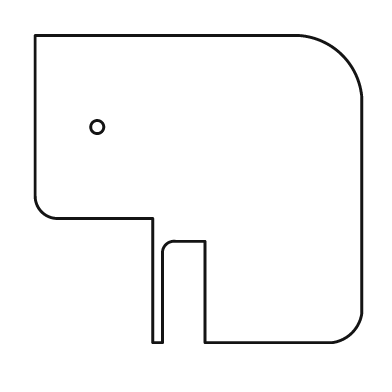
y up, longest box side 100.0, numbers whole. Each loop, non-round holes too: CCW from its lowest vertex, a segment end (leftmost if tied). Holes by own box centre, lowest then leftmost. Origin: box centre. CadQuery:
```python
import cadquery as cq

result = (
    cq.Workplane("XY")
    .moveTo(-14.0, -47.0)
    .lineTo(-11.0, -47.0)
    .lineTo(-11.0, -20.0)
    .threePointArc((-10.0, -17.0), (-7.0, -16.0))
    .lineTo(2.0, -16.0)
    .lineTo(2.0, -47.0)
    .lineTo(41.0, -47.0)
    .threePointArc((47.0, -44.0), (50.0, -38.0))
    .lineTo(50.0, 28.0)
    .threePointArc((44.0, 41.0), (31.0, 47.0))
    .lineTo(-50.0, 47.0)
    .lineTo(-50.0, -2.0)
    .threePointArc((-48.0, -7.0), (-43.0, -9.0))
    .lineTo(-14.0, -9.0)
    .close()
    .moveTo(-31.0, 19.0)
    .circle(2.0)
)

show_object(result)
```